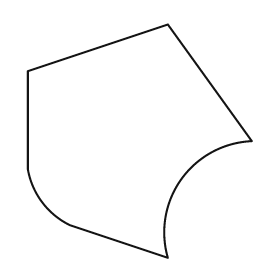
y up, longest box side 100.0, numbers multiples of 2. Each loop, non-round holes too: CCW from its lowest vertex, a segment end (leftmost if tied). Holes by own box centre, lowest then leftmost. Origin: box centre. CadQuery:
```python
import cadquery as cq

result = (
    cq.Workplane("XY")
    .moveTo(12.0, -50.0)
    .threePointArc((18.0, -16.0), (48.0, 0.0))
    .lineTo(12.0, 50.0)
    .lineTo(-48.0, 30.0)
    .lineTo(-48.0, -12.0)
    .threePointArc((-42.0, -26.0), (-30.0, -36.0))
    .close()
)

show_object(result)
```